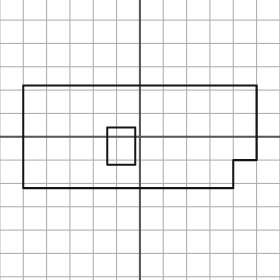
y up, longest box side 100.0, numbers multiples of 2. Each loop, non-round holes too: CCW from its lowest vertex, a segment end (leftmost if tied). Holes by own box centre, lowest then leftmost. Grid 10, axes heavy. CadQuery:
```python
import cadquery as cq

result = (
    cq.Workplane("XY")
    .moveTo(-50.0, -22.0)
    .lineTo(40.0, -22.0)
    .lineTo(40.0, -10.0)
    .lineTo(50.0, -10.0)
    .lineTo(50.0, 22.0)
    .lineTo(-50.0, 22.0)
    .close()
    .moveTo(-14.0, -12.0)
    .lineTo(-2.0, -12.0)
    .lineTo(-2.0, 4.0)
    .lineTo(-14.0, 4.0)
    .close()
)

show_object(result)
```